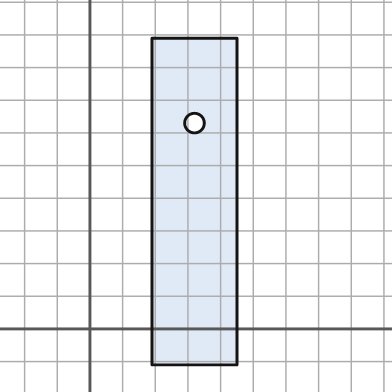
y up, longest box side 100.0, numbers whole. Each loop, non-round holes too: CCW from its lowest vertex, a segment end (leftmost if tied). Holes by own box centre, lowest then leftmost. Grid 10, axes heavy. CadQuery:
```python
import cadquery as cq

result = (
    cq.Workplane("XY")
    .moveTo(19.0, -11.0)
    .lineTo(45.0, -11.0)
    .lineTo(45.0, 89.0)
    .lineTo(19.0, 89.0)
    .close()
    .moveTo(32.0, 63.0)
    .circle(3.0)
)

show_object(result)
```